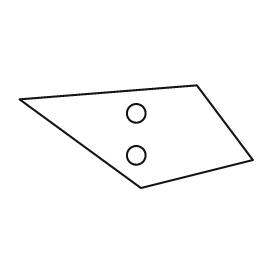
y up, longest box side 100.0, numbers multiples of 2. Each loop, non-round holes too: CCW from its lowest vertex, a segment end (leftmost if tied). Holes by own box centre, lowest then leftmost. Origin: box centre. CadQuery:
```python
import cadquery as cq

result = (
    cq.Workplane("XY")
    .moveTo(2.0, -22.0)
    .lineTo(50.0, -10.0)
    .lineTo(26.0, 22.0)
    .lineTo(-50.0, 16.0)
    .close()
    .moveTo(0.0, -8.0)
    .circle(4.0)
    .moveTo(0.0, 10.0)
    .circle(4.0)
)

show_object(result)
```